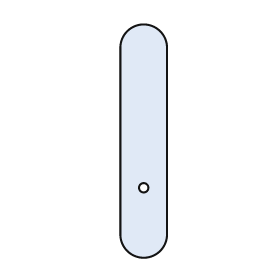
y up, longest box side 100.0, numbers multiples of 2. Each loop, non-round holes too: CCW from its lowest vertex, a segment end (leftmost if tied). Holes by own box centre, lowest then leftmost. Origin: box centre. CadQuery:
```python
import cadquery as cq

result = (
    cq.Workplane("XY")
    .moveTo(-10.0, -40.0)
    .threePointArc((0.0, -50.0), (10.0, -40.0))
    .lineTo(10.0, 40.0)
    .threePointArc((0.0, 50.0), (-10.0, 40.0))
    .close()
    .moveTo(0.0, -20.0)
    .circle(2.0)
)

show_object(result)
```